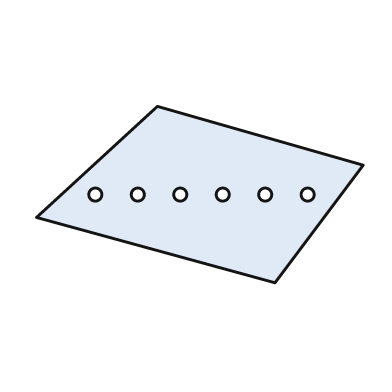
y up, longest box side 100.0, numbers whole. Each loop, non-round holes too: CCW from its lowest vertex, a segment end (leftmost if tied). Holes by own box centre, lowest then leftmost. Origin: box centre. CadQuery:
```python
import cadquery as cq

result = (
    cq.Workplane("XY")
    .moveTo(23.0, -27.0)
    .lineTo(50.0, 9.0)
    .lineTo(-13.0, 27.0)
    .lineTo(-50.0, -7.0)
    .close()
    .moveTo(-32.0, 0.0)
    .circle(2.0)
    .moveTo(-19.0, 0.0)
    .circle(2.0)
    .moveTo(-6.0, 0.0)
    .circle(2.0)
    .moveTo(7.0, 0.0)
    .circle(2.0)
    .moveTo(20.0, 0.0)
    .circle(2.0)
    .moveTo(33.0, 0.0)
    .circle(2.0)
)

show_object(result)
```